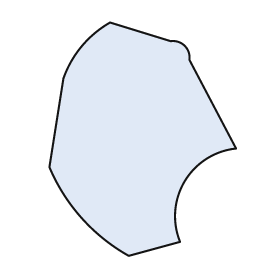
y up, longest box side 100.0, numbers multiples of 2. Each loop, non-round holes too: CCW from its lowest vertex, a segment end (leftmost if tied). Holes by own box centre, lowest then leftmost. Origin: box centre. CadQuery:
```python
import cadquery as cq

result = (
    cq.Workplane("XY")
    .moveTo(-6.0, -50.0)
    .lineTo(16.0, -44.0)
    .threePointArc((18.0, -18.0), (40.0, -4.0))
    .lineTo(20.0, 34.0)
    .threePointArc((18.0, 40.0), (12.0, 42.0))
    .lineTo(-14.0, 50.0)
    .threePointArc((-26.0, 40.0), (-34.0, 26.0))
    .lineTo(-40.0, -12.0)
    .threePointArc((-26.0, -34.0), (-6.0, -50.0))
    .close()
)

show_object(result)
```